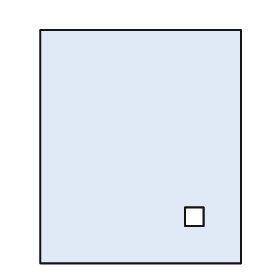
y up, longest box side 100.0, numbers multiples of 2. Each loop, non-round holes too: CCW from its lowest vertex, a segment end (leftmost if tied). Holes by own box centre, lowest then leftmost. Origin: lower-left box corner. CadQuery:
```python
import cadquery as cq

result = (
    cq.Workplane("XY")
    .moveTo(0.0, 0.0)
    .lineTo(86.0, 0.0)
    .lineTo(86.0, 100.0)
    .lineTo(0.0, 100.0)
    .close()
    .moveTo(62.0, 16.0)
    .lineTo(70.0, 16.0)
    .lineTo(70.0, 24.0)
    .lineTo(62.0, 24.0)
    .close()
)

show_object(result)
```